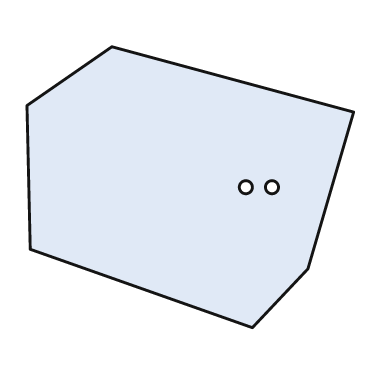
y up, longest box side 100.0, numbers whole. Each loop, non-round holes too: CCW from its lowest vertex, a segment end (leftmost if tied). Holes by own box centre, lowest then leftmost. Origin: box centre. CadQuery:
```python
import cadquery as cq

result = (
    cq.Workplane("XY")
    .moveTo(19.0, -43.0)
    .lineTo(36.0, -25.0)
    .lineTo(50.0, 23.0)
    .lineTo(-24.0, 43.0)
    .lineTo(-50.0, 25.0)
    .lineTo(-49.0, -19.0)
    .close()
    .moveTo(17.0, 0.0)
    .circle(2.0)
    .moveTo(25.0, 0.0)
    .circle(2.0)
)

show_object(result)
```